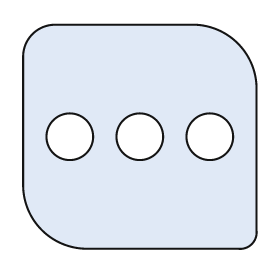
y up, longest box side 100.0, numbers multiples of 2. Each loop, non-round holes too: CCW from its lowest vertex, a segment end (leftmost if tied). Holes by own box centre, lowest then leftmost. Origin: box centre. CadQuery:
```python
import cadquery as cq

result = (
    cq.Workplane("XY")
    .moveTo(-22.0, -48.0)
    .lineTo(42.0, -48.0)
    .threePointArc((48.0, -46.0), (50.0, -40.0))
    .lineTo(50.0, 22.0)
    .threePointArc((42.0, 40.0), (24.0, 48.0))
    .lineTo(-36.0, 48.0)
    .threePointArc((-46.0, 44.0), (-50.0, 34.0))
    .lineTo(-50.0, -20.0)
    .threePointArc((-42.0, -40.0), (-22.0, -48.0))
    .close()
    .moveTo(-30.0, 0.0)
    .circle(10.0)
    .moveTo(0.0, 0.0)
    .circle(10.0)
    .moveTo(30.0, 0.0)
    .circle(10.0)
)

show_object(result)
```